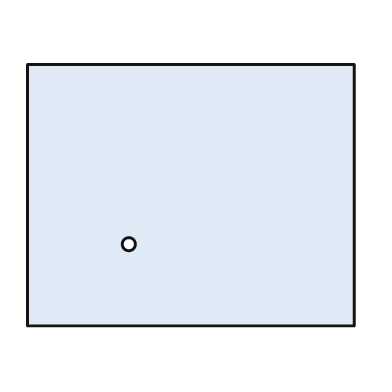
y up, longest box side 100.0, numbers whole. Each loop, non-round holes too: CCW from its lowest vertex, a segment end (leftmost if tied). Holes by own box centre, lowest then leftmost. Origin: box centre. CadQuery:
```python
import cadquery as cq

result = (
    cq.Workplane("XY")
    .moveTo(-50.0, -40.0)
    .lineTo(50.0, -40.0)
    .lineTo(50.0, 40.0)
    .lineTo(-50.0, 40.0)
    .close()
    .moveTo(-19.0, -15.0)
    .circle(2.0)
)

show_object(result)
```